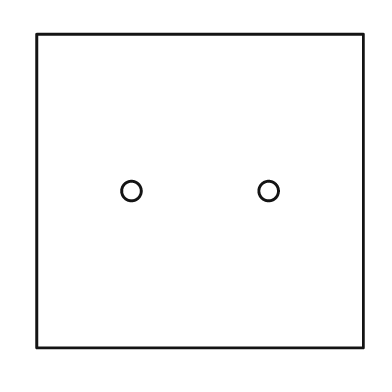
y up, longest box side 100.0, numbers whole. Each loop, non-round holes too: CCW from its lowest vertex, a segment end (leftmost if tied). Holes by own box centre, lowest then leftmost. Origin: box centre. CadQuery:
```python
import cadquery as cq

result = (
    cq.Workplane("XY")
    .moveTo(-50.0, -48.0)
    .lineTo(50.0, -48.0)
    .lineTo(50.0, 48.0)
    .lineTo(-50.0, 48.0)
    .close()
    .moveTo(-21.0, 0.0)
    .circle(3.0)
    .moveTo(21.0, 0.0)
    .circle(3.0)
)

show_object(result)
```